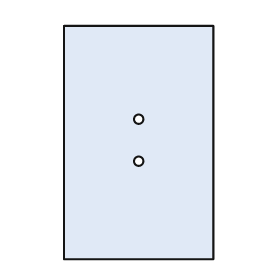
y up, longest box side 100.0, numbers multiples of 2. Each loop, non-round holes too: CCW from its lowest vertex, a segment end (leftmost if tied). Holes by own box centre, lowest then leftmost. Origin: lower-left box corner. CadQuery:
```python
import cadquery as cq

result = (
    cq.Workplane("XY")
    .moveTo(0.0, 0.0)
    .lineTo(64.0, 0.0)
    .lineTo(64.0, 100.0)
    .lineTo(0.0, 100.0)
    .close()
    .moveTo(32.0, 42.0)
    .circle(2.0)
    .moveTo(32.0, 60.0)
    .circle(2.0)
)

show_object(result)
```